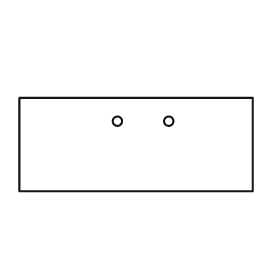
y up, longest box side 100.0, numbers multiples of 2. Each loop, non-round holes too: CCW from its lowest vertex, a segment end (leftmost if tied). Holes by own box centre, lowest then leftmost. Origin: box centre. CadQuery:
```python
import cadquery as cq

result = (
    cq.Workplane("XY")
    .moveTo(-50.0, -20.0)
    .lineTo(50.0, -20.0)
    .lineTo(50.0, 20.0)
    .lineTo(-50.0, 20.0)
    .close()
    .moveTo(-8.0, 10.0)
    .circle(2.0)
    .moveTo(14.0, 10.0)
    .circle(2.0)
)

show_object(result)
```